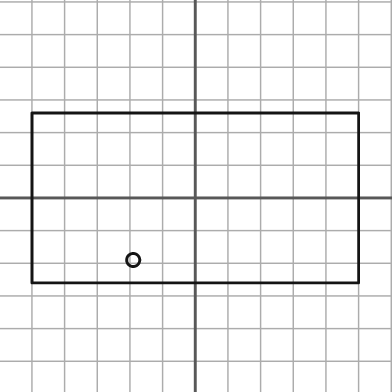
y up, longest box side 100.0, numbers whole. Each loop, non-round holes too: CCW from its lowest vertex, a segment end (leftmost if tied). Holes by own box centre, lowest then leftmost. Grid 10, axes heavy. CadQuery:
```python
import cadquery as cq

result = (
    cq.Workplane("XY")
    .moveTo(-50.0, -26.0)
    .lineTo(50.0, -26.0)
    .lineTo(50.0, 26.0)
    .lineTo(-50.0, 26.0)
    .close()
    .moveTo(-19.0, -19.0)
    .circle(2.0)
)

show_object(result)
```